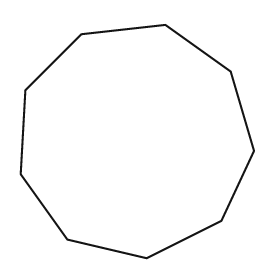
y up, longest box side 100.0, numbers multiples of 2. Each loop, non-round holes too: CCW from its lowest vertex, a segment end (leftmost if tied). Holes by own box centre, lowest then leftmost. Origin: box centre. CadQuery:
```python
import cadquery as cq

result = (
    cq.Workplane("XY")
    .moveTo(4.0, -50.0)
    .lineTo(36.0, -34.0)
    .lineTo(50.0, -4.0)
    .lineTo(40.0, 30.0)
    .lineTo(12.0, 50.0)
    .lineTo(-24.0, 46.0)
    .lineTo(-48.0, 22.0)
    .lineTo(-50.0, -14.0)
    .lineTo(-30.0, -42.0)
    .close()
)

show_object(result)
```